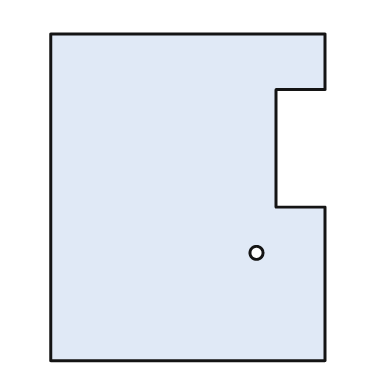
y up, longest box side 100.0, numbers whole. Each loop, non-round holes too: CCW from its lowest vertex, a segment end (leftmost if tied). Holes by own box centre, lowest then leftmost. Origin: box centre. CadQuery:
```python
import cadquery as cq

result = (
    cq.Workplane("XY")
    .moveTo(-42.0, -50.0)
    .lineTo(42.0, -50.0)
    .lineTo(42.0, -3.0)
    .lineTo(27.0, -3.0)
    .lineTo(27.0, 33.0)
    .lineTo(42.0, 33.0)
    .lineTo(42.0, 50.0)
    .lineTo(-42.0, 50.0)
    .close()
    .moveTo(21.0, -17.0)
    .circle(2.0)
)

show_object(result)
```